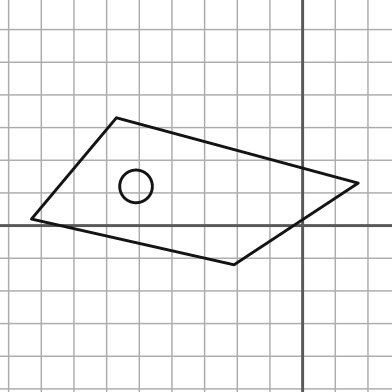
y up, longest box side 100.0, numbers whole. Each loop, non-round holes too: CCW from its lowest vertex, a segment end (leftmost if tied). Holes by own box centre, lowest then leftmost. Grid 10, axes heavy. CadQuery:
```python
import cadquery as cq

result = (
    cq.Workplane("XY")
    .moveTo(-21.0, -12.0)
    .lineTo(17.0, 13.0)
    .lineTo(-57.0, 33.0)
    .lineTo(-83.0, 2.0)
    .close()
    .moveTo(-51.0, 12.0)
    .circle(5.0)
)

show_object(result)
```